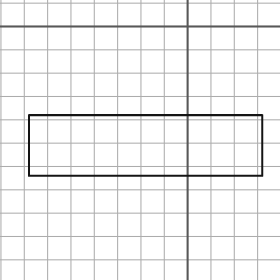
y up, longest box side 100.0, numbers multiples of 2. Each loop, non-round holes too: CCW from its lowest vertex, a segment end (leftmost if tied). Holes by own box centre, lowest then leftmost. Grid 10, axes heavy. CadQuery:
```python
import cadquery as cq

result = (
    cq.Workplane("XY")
    .moveTo(-68.0, -64.0)
    .lineTo(32.0, -64.0)
    .lineTo(32.0, -38.0)
    .lineTo(-68.0, -38.0)
    .close()
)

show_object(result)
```